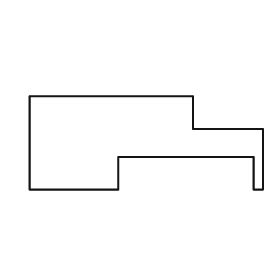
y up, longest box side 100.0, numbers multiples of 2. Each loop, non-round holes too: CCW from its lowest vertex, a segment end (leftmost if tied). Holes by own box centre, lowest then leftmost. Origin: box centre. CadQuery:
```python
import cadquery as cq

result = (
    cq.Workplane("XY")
    .moveTo(-50.0, -20.0)
    .lineTo(-12.0, -20.0)
    .lineTo(-12.0, -6.0)
    .lineTo(46.0, -6.0)
    .lineTo(46.0, -20.0)
    .lineTo(50.0, -20.0)
    .lineTo(50.0, 6.0)
    .lineTo(20.0, 6.0)
    .lineTo(20.0, 20.0)
    .lineTo(-50.0, 20.0)
    .close()
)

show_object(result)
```